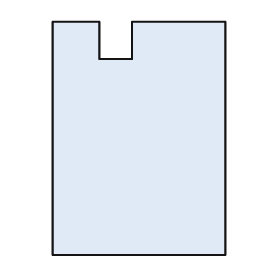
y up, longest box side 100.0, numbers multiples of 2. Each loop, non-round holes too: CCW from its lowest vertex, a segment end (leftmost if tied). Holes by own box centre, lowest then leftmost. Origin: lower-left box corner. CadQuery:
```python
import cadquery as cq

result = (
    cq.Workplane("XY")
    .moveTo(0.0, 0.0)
    .lineTo(74.0, 0.0)
    .lineTo(74.0, 100.0)
    .lineTo(34.0, 100.0)
    .lineTo(34.0, 84.0)
    .lineTo(20.0, 84.0)
    .lineTo(20.0, 100.0)
    .lineTo(0.0, 100.0)
    .close()
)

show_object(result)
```